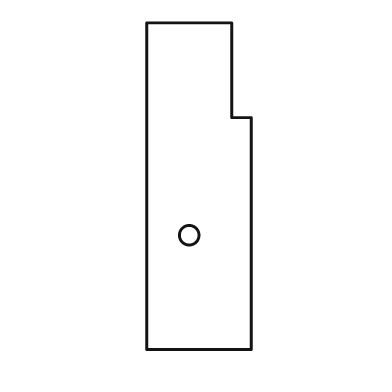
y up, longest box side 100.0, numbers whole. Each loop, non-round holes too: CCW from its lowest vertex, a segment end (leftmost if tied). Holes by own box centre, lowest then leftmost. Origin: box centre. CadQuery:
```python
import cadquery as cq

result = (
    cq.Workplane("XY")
    .moveTo(-16.0, -50.0)
    .lineTo(16.0, -50.0)
    .lineTo(16.0, 21.0)
    .lineTo(10.0, 21.0)
    .lineTo(10.0, 50.0)
    .lineTo(-16.0, 50.0)
    .close()
    .moveTo(-3.0, -15.0)
    .circle(3.0)
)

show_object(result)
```